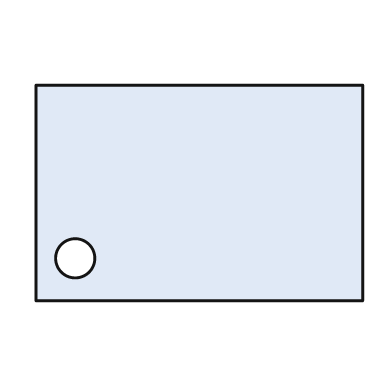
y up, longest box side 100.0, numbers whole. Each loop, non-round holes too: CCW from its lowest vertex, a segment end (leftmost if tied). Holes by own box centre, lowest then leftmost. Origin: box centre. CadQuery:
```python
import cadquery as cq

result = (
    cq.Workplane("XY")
    .moveTo(-50.0, -33.0)
    .lineTo(50.0, -33.0)
    .lineTo(50.0, 33.0)
    .lineTo(-50.0, 33.0)
    .close()
    .moveTo(-38.0, -20.0)
    .circle(6.0)
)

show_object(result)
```